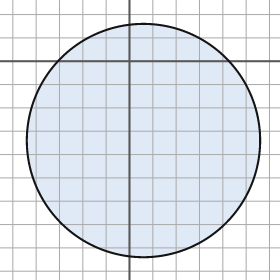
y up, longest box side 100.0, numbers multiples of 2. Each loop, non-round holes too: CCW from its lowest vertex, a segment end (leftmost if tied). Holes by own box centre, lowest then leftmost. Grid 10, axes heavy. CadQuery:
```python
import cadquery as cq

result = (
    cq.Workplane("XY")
    .moveTo(6.0, -34.0)
    .circle(50.0)
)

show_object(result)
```